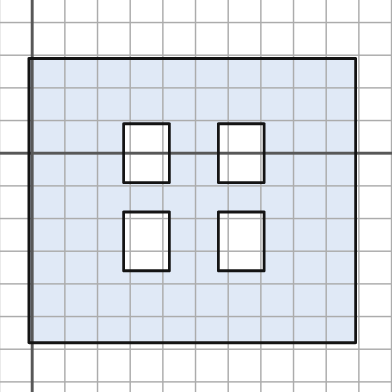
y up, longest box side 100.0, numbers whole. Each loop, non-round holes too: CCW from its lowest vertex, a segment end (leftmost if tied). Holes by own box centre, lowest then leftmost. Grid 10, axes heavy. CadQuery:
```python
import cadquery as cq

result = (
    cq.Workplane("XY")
    .moveTo(-1.0, -58.0)
    .lineTo(99.0, -58.0)
    .lineTo(99.0, 29.0)
    .lineTo(-1.0, 29.0)
    .close()
    .moveTo(28.0, -36.0)
    .lineTo(42.0, -36.0)
    .lineTo(42.0, -18.0)
    .lineTo(28.0, -18.0)
    .close()
    .moveTo(57.0, -36.0)
    .lineTo(71.0, -36.0)
    .lineTo(71.0, -18.0)
    .lineTo(57.0, -18.0)
    .close()
    .moveTo(28.0, -9.0)
    .lineTo(42.0, -9.0)
    .lineTo(42.0, 9.0)
    .lineTo(28.0, 9.0)
    .close()
    .moveTo(57.0, -9.0)
    .lineTo(71.0, -9.0)
    .lineTo(71.0, 9.0)
    .lineTo(57.0, 9.0)
    .close()
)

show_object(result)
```